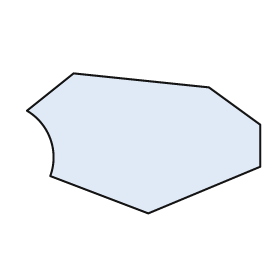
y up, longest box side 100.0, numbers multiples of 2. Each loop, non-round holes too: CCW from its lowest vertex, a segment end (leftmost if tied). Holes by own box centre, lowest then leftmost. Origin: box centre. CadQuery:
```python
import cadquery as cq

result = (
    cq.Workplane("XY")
    .moveTo(2.0, -30.0)
    .lineTo(50.0, -10.0)
    .lineTo(50.0, 8.0)
    .lineTo(28.0, 24.0)
    .lineTo(-30.0, 30.0)
    .lineTo(-50.0, 14.0)
    .threePointArc((-40.0, 2.0), (-40.0, -14.0))
    .close()
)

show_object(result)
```